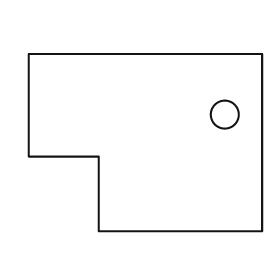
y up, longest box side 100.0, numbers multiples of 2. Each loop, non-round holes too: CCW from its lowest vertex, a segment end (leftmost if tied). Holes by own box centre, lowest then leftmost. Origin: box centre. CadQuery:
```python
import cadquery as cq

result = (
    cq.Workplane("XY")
    .moveTo(-20.0, -38.0)
    .lineTo(50.0, -38.0)
    .lineTo(50.0, 38.0)
    .lineTo(-50.0, 38.0)
    .lineTo(-50.0, -6.0)
    .lineTo(-20.0, -6.0)
    .close()
    .moveTo(34.0, 12.0)
    .circle(6.0)
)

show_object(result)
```